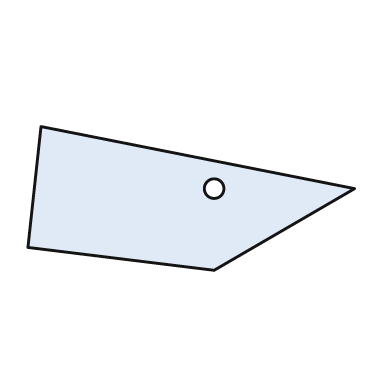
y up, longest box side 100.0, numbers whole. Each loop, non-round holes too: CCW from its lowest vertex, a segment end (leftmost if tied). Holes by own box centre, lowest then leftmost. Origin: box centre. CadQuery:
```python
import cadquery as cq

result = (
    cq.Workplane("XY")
    .moveTo(7.0, -22.0)
    .lineTo(50.0, 3.0)
    .lineTo(-46.0, 22.0)
    .lineTo(-50.0, -15.0)
    .close()
    .moveTo(7.0, 3.0)
    .circle(3.0)
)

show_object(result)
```